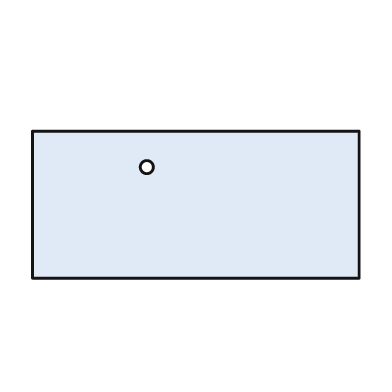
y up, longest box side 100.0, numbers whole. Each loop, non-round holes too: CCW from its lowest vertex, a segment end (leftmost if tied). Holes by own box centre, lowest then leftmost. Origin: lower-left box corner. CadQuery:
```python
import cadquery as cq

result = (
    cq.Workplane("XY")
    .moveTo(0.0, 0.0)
    .lineTo(100.0, 0.0)
    .lineTo(100.0, 45.0)
    .lineTo(0.0, 45.0)
    .close()
    .moveTo(35.0, 34.0)
    .circle(2.0)
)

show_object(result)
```